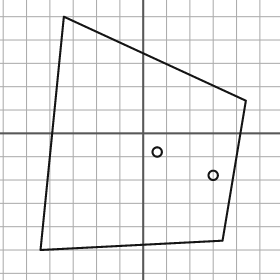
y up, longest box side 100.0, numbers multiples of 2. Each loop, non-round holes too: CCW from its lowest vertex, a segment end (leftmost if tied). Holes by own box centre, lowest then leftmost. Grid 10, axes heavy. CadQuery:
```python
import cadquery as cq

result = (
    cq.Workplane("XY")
    .moveTo(-44.0, -50.0)
    .lineTo(34.0, -46.0)
    .lineTo(44.0, 14.0)
    .lineTo(-34.0, 50.0)
    .close()
    .moveTo(30.0, -18.0)
    .circle(2.0)
    .moveTo(6.0, -8.0)
    .circle(2.0)
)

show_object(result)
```